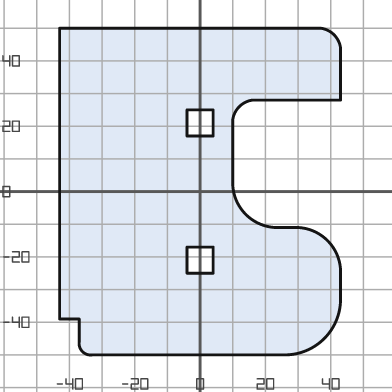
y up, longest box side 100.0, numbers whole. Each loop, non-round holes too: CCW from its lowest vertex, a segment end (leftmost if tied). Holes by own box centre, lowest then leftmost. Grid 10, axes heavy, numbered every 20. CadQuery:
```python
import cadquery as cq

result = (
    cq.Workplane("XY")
    .moveTo(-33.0, -50.0)
    .lineTo(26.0, -50.0)
    .threePointArc((38.0, -45.0), (43.0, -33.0))
    .lineTo(43.0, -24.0)
    .threePointArc((39.0, -15.0), (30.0, -11.0))
    .lineTo(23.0, -11.0)
    .threePointArc((14.0, -7.0), (10.0, 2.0))
    .lineTo(10.0, 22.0)
    .threePointArc((12.0, 26.0), (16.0, 28.0))
    .lineTo(43.0, 28.0)
    .lineTo(43.0, 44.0)
    .threePointArc((41.0, 48.0), (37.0, 50.0))
    .lineTo(-43.0, 50.0)
    .lineTo(-43.0, -39.0)
    .lineTo(-37.0, -39.0)
    .lineTo(-37.0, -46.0)
    .threePointArc((-36.0, -49.0), (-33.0, -50.0))
    .close()
    .moveTo(-4.0, -25.0)
    .lineTo(4.0, -25.0)
    .lineTo(4.0, -17.0)
    .lineTo(-4.0, -17.0)
    .close()
    .moveTo(-4.0, 17.0)
    .lineTo(4.0, 17.0)
    .lineTo(4.0, 25.0)
    .lineTo(-4.0, 25.0)
    .close()
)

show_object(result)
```